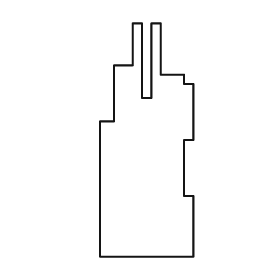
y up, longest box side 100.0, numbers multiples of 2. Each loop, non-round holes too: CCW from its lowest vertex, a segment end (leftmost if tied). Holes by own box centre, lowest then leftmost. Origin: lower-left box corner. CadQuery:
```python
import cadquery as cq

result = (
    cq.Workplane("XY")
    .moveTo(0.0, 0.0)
    .lineTo(40.0, 0.0)
    .lineTo(40.0, 26.0)
    .lineTo(36.0, 26.0)
    .lineTo(36.0, 50.0)
    .lineTo(40.0, 50.0)
    .lineTo(40.0, 74.0)
    .lineTo(36.0, 74.0)
    .lineTo(36.0, 78.0)
    .lineTo(26.0, 78.0)
    .lineTo(26.0, 100.0)
    .lineTo(22.0, 100.0)
    .lineTo(22.0, 68.0)
    .lineTo(18.0, 68.0)
    .lineTo(18.0, 100.0)
    .lineTo(14.0, 100.0)
    .lineTo(14.0, 82.0)
    .lineTo(6.0, 82.0)
    .lineTo(6.0, 58.0)
    .lineTo(0.0, 58.0)
    .close()
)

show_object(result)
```